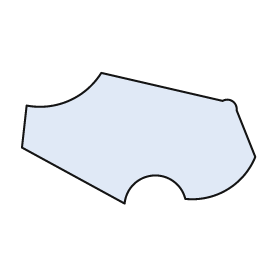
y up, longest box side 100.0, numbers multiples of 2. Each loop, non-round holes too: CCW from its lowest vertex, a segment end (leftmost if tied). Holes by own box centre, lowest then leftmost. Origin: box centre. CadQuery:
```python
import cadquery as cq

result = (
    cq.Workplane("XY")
    .moveTo(-6.0, -28.0)
    .threePointArc((6.0, -16.0), (20.0, -26.0))
    .threePointArc((38.0, -22.0), (50.0, -8.0))
    .lineTo(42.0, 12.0)
    .threePointArc((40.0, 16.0), (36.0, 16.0))
    .lineTo(-16.0, 28.0)
    .threePointArc((-30.0, 16.0), (-48.0, 14.0))
    .lineTo(-50.0, -4.0)
    .close()
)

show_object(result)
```